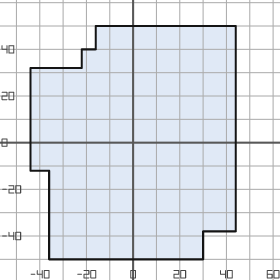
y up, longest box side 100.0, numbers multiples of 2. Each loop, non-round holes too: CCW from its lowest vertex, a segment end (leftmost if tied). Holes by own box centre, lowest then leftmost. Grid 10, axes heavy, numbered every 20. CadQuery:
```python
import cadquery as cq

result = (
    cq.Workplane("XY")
    .moveTo(-36.0, -50.0)
    .lineTo(30.0, -50.0)
    .lineTo(30.0, -38.0)
    .lineTo(44.0, -38.0)
    .lineTo(44.0, 50.0)
    .lineTo(-16.0, 50.0)
    .lineTo(-16.0, 40.0)
    .lineTo(-22.0, 40.0)
    .lineTo(-22.0, 32.0)
    .lineTo(-44.0, 32.0)
    .lineTo(-44.0, -12.0)
    .lineTo(-36.0, -12.0)
    .close()
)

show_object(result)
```